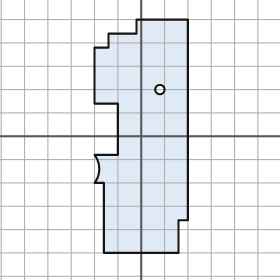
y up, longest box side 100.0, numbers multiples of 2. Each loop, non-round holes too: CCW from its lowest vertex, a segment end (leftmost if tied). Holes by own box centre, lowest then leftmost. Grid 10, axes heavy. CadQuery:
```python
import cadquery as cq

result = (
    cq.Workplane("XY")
    .moveTo(-16.0, -50.0)
    .lineTo(16.0, -50.0)
    .lineTo(16.0, -36.0)
    .lineTo(20.0, -36.0)
    .lineTo(20.0, 50.0)
    .lineTo(-2.0, 50.0)
    .lineTo(-2.0, 44.0)
    .lineTo(-14.0, 44.0)
    .lineTo(-14.0, 38.0)
    .lineTo(-20.0, 38.0)
    .lineTo(-20.0, 14.0)
    .lineTo(-10.0, 14.0)
    .lineTo(-10.0, -8.0)
    .lineTo(-20.0, -8.0)
    .threePointArc((-18.0, -14.0), (-20.0, -20.0))
    .lineTo(-16.0, -20.0)
    .close()
    .moveTo(8.0, 20.0)
    .circle(2.0)
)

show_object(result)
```